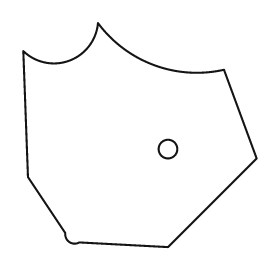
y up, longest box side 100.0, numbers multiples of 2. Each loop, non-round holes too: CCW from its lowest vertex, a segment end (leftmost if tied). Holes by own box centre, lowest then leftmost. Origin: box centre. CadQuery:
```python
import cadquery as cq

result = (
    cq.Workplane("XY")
    .moveTo(12.0, -48.0)
    .lineTo(50.0, -10.0)
    .lineTo(36.0, 28.0)
    .threePointArc((6.0, 30.0), (-18.0, 48.0))
    .threePointArc((-30.0, 32.0), (-50.0, 36.0))
    .lineTo(-48.0, -18.0)
    .lineTo(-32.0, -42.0)
    .threePointArc((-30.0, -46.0), (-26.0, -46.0))
    .close()
    .moveTo(12.0, -6.0)
    .circle(4.0)
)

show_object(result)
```